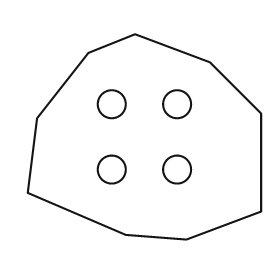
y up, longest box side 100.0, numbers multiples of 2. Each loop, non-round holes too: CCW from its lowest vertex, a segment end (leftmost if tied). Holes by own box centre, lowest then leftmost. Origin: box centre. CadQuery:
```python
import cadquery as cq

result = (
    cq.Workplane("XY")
    .moveTo(18.0, -44.0)
    .lineTo(50.0, -32.0)
    .lineTo(50.0, 10.0)
    .lineTo(28.0, 32.0)
    .lineTo(-4.0, 44.0)
    .lineTo(-24.0, 36.0)
    .lineTo(-46.0, 8.0)
    .lineTo(-50.0, -24.0)
    .lineTo(-8.0, -42.0)
    .close()
    .moveTo(-14.0, -14.0)
    .circle(6.0)
    .moveTo(14.0, -14.0)
    .circle(6.0)
    .moveTo(-14.0, 14.0)
    .circle(6.0)
    .moveTo(14.0, 14.0)
    .circle(6.0)
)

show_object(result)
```